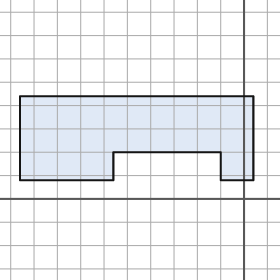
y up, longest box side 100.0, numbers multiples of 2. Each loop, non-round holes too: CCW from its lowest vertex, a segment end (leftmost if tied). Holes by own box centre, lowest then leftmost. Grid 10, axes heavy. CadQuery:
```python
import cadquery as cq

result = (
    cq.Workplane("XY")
    .moveTo(-96.0, 8.0)
    .lineTo(-56.0, 8.0)
    .lineTo(-56.0, 20.0)
    .lineTo(-10.0, 20.0)
    .lineTo(-10.0, 8.0)
    .lineTo(4.0, 8.0)
    .lineTo(4.0, 44.0)
    .lineTo(-96.0, 44.0)
    .close()
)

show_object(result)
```